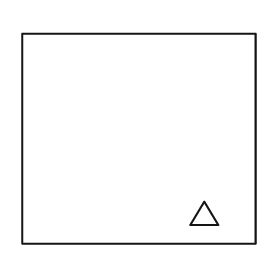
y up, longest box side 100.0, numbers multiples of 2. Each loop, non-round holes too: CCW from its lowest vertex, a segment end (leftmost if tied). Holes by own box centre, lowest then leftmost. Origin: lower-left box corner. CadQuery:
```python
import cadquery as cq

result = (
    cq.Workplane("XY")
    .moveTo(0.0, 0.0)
    .lineTo(100.0, 0.0)
    .lineTo(100.0, 90.0)
    .lineTo(0.0, 90.0)
    .close()
    .moveTo(72.0, 8.0)
    .lineTo(84.0, 8.0)
    .lineTo(78.0, 18.0)
    .close()
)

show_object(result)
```